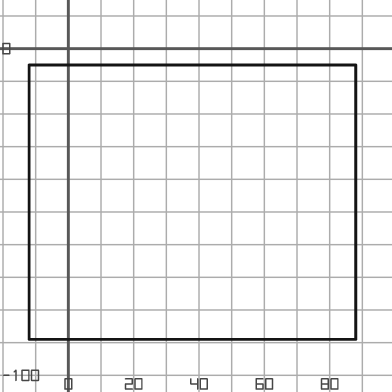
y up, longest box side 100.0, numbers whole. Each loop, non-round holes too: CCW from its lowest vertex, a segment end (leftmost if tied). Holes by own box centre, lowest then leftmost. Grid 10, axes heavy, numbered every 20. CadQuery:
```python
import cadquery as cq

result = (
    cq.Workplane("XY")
    .moveTo(-12.0, -89.0)
    .lineTo(88.0, -89.0)
    .lineTo(88.0, -5.0)
    .lineTo(-12.0, -5.0)
    .close()
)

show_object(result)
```